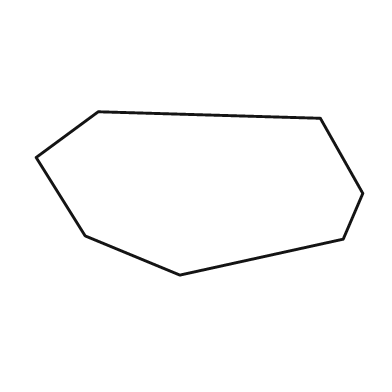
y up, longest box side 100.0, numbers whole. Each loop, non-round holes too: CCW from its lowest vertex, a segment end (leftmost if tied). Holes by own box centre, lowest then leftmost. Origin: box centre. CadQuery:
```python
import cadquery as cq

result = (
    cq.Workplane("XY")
    .moveTo(-6.0, -25.0)
    .lineTo(44.0, -14.0)
    .lineTo(50.0, 0.0)
    .lineTo(37.0, 23.0)
    .lineTo(-31.0, 25.0)
    .lineTo(-50.0, 11.0)
    .lineTo(-35.0, -13.0)
    .close()
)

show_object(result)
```